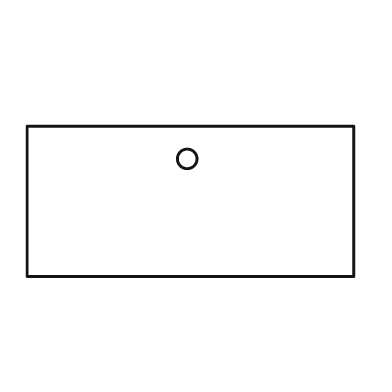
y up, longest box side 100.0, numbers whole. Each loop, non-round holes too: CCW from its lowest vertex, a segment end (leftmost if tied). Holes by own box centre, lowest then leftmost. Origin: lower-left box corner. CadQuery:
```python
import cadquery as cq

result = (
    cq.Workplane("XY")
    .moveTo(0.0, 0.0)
    .lineTo(100.0, 0.0)
    .lineTo(100.0, 46.0)
    .lineTo(0.0, 46.0)
    .close()
    .moveTo(49.0, 36.0)
    .circle(3.0)
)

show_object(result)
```